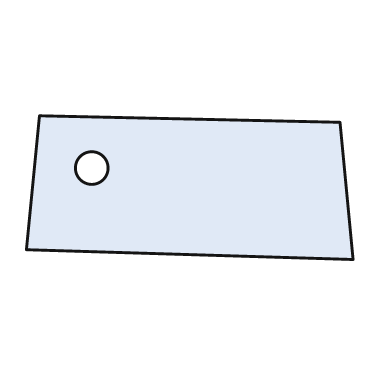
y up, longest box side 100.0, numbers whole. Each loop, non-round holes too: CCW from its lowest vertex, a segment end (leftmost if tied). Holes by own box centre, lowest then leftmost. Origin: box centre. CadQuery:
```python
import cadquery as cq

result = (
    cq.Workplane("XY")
    .moveTo(50.0, -22.0)
    .lineTo(46.0, 20.0)
    .lineTo(-46.0, 22.0)
    .lineTo(-50.0, -19.0)
    .close()
    .moveTo(-30.0, 6.0)
    .circle(5.0)
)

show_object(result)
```